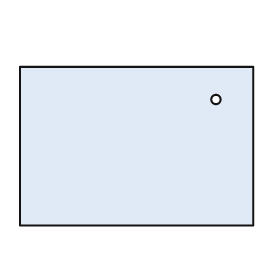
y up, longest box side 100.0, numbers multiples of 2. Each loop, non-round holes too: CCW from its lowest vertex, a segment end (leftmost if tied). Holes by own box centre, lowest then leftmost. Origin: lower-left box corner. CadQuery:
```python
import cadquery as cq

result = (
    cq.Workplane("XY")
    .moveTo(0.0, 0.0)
    .lineTo(100.0, 0.0)
    .lineTo(100.0, 68.0)
    .lineTo(0.0, 68.0)
    .close()
    .moveTo(84.0, 54.0)
    .circle(2.0)
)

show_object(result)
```